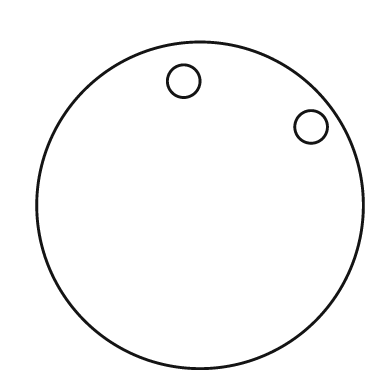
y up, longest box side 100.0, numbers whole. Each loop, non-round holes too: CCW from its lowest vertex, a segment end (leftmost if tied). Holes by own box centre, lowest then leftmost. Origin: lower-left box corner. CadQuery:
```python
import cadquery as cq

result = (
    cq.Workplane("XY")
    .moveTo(50.0, 50.0)
    .circle(50.0)
    .moveTo(84.0, 74.0)
    .circle(5.0)
    .moveTo(45.0, 88.0)
    .circle(5.0)
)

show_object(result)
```